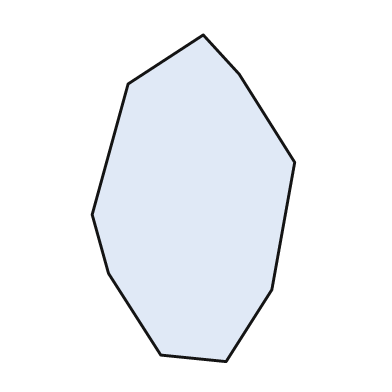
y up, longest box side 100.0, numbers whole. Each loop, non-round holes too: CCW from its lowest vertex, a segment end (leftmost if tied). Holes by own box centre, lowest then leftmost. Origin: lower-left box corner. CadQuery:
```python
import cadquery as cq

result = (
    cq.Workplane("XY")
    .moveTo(41.0, 0.0)
    .lineTo(55.0, 22.0)
    .lineTo(62.0, 61.0)
    .lineTo(45.0, 88.0)
    .lineTo(34.0, 100.0)
    .lineTo(11.0, 85.0)
    .lineTo(0.0, 45.0)
    .lineTo(5.0, 27.0)
    .lineTo(21.0, 2.0)
    .close()
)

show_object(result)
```